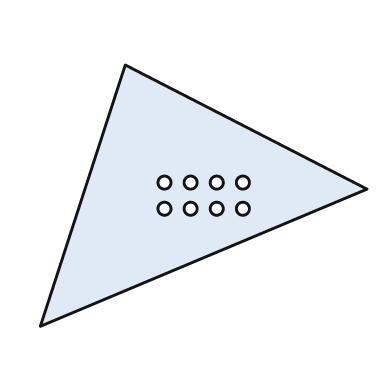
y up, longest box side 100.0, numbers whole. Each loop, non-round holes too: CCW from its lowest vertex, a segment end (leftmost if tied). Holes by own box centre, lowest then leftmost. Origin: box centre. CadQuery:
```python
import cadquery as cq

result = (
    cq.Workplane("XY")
    .moveTo(-50.0, -40.0)
    .lineTo(50.0, 2.0)
    .lineTo(-24.0, 40.0)
    .close()
    .moveTo(-12.0, -4.0)
    .circle(2.0)
    .moveTo(-4.0, -4.0)
    .circle(2.0)
    .moveTo(4.0, -4.0)
    .circle(2.0)
    .moveTo(12.0, -4.0)
    .circle(2.0)
    .moveTo(-12.0, 4.0)
    .circle(2.0)
    .moveTo(-4.0, 4.0)
    .circle(2.0)
    .moveTo(4.0, 4.0)
    .circle(2.0)
    .moveTo(12.0, 4.0)
    .circle(2.0)
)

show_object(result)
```